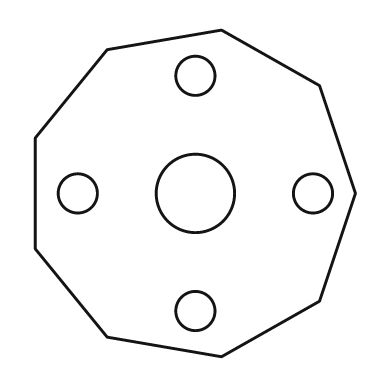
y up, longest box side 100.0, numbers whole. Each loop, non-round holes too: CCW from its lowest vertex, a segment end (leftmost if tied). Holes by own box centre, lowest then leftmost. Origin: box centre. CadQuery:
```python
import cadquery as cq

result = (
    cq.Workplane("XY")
    .moveTo(8.0, -50.0)
    .lineTo(38.0, -33.0)
    .lineTo(49.0, 0.0)
    .lineTo(38.0, 33.0)
    .lineTo(8.0, 50.0)
    .lineTo(-27.0, 44.0)
    .lineTo(-49.0, 17.0)
    .lineTo(-49.0, -17.0)
    .lineTo(-27.0, -44.0)
    .close()
    .moveTo(0.0, -36.0)
    .circle(6.0)
    .moveTo(-36.0, 0.0)
    .circle(6.0)
    .moveTo(0.0, 0.0)
    .circle(12.0)
    .moveTo(36.0, 0.0)
    .circle(6.0)
    .moveTo(0.0, 36.0)
    .circle(6.0)
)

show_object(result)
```